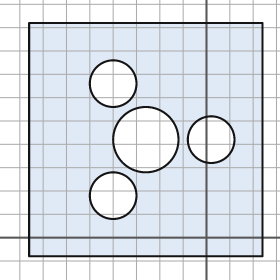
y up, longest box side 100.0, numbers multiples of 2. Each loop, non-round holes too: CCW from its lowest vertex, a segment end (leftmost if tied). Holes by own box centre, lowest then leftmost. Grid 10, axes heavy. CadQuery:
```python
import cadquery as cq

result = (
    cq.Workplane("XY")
    .moveTo(-76.0, -8.0)
    .lineTo(24.0, -8.0)
    .lineTo(24.0, 92.0)
    .lineTo(-76.0, 92.0)
    .close()
    .moveTo(-40.0, 18.0)
    .circle(10.0)
    .moveTo(-26.0, 42.0)
    .circle(14.0)
    .moveTo(2.0, 42.0)
    .circle(10.0)
    .moveTo(-40.0, 66.0)
    .circle(10.0)
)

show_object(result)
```